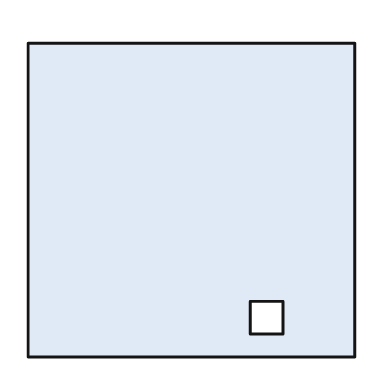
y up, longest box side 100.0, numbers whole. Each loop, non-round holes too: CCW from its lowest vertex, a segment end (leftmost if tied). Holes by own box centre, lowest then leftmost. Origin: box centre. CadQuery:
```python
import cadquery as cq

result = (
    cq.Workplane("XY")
    .moveTo(-50.0, -48.0)
    .lineTo(50.0, -48.0)
    .lineTo(50.0, 48.0)
    .lineTo(-50.0, 48.0)
    .close()
    .moveTo(18.0, -41.0)
    .lineTo(28.0, -41.0)
    .lineTo(28.0, -31.0)
    .lineTo(18.0, -31.0)
    .close()
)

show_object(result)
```